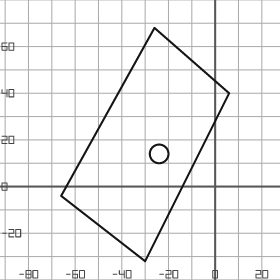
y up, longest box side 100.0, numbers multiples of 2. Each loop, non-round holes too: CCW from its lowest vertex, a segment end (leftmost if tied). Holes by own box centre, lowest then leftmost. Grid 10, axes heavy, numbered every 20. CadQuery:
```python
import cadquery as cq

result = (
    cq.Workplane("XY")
    .moveTo(-30.0, -32.0)
    .lineTo(6.0, 40.0)
    .lineTo(-26.0, 68.0)
    .lineTo(-66.0, -4.0)
    .close()
    .moveTo(-24.0, 14.0)
    .circle(4.0)
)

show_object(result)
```